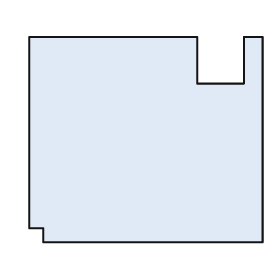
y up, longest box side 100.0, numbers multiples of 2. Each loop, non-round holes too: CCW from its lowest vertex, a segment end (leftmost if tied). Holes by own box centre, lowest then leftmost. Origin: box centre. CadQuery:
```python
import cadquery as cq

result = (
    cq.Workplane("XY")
    .moveTo(-44.0, -44.0)
    .lineTo(50.0, -44.0)
    .lineTo(50.0, 44.0)
    .lineTo(42.0, 44.0)
    .lineTo(42.0, 24.0)
    .lineTo(22.0, 24.0)
    .lineTo(22.0, 44.0)
    .lineTo(-50.0, 44.0)
    .lineTo(-50.0, -38.0)
    .lineTo(-44.0, -38.0)
    .close()
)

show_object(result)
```